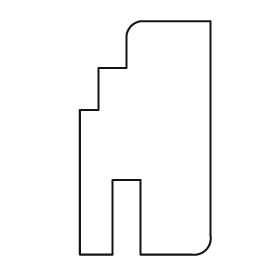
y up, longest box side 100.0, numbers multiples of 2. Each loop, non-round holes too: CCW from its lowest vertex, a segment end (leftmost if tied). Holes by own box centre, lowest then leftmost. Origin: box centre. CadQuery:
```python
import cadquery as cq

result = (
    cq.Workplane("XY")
    .moveTo(-28.0, -50.0)
    .lineTo(-14.0, -50.0)
    .lineTo(-14.0, -18.0)
    .lineTo(-2.0, -18.0)
    .lineTo(-2.0, -50.0)
    .lineTo(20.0, -50.0)
    .threePointArc((26.0, -48.0), (28.0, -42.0))
    .lineTo(28.0, 50.0)
    .lineTo(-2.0, 50.0)
    .threePointArc((-6.0, 48.0), (-8.0, 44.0))
    .lineTo(-8.0, 30.0)
    .lineTo(-20.0, 30.0)
    .lineTo(-20.0, 12.0)
    .lineTo(-28.0, 12.0)
    .close()
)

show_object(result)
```